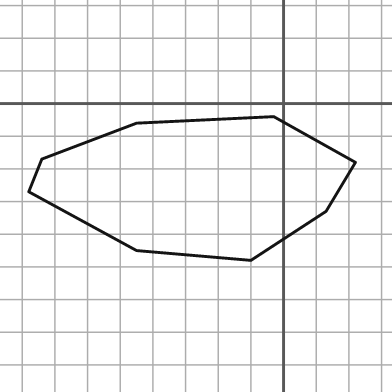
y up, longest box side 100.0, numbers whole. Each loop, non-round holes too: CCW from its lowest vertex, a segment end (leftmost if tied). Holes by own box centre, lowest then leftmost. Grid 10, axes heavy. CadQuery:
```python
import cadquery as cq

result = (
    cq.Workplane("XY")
    .moveTo(-10.0, -48.0)
    .lineTo(13.0, -33.0)
    .lineTo(22.0, -18.0)
    .lineTo(-3.0, -4.0)
    .lineTo(-45.0, -6.0)
    .lineTo(-74.0, -17.0)
    .lineTo(-78.0, -27.0)
    .lineTo(-45.0, -45.0)
    .close()
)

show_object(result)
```